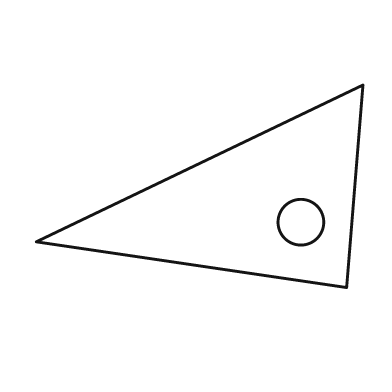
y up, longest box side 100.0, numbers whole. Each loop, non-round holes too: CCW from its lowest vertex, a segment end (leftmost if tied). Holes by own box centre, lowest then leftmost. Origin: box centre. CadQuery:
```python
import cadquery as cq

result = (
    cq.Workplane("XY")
    .moveTo(45.0, -31.0)
    .lineTo(50.0, 31.0)
    .lineTo(-50.0, -17.0)
    .close()
    .moveTo(31.0, -11.0)
    .circle(7.0)
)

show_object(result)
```